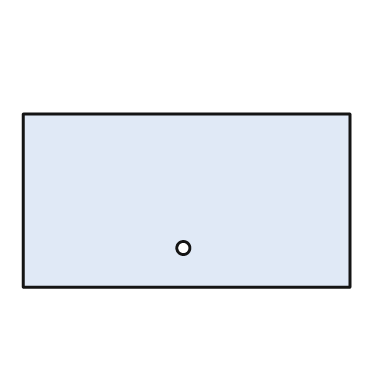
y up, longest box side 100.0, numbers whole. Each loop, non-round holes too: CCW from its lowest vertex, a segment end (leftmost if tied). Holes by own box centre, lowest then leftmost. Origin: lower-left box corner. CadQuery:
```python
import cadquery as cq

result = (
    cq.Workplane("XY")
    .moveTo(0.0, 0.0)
    .lineTo(100.0, 0.0)
    .lineTo(100.0, 53.0)
    .lineTo(0.0, 53.0)
    .close()
    .moveTo(49.0, 12.0)
    .circle(2.0)
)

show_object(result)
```